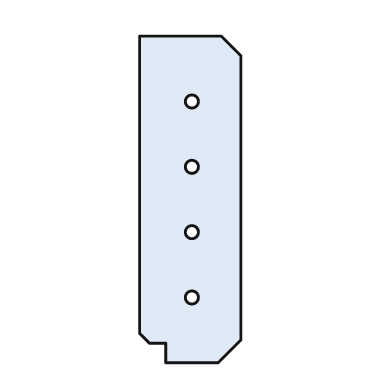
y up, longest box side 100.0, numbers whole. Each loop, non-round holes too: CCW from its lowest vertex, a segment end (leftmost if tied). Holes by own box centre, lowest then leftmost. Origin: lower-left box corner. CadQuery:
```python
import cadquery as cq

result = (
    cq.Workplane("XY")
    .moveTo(8.0, 0.0)
    .lineTo(24.0, 0.0)
    .lineTo(31.0, 7.0)
    .lineTo(31.0, 94.0)
    .lineTo(25.0, 100.0)
    .lineTo(0.0, 100.0)
    .lineTo(0.0, 9.0)
    .lineTo(3.0, 6.0)
    .lineTo(8.0, 6.0)
    .close()
    .moveTo(16.0, 20.0)
    .circle(2.0)
    .moveTo(16.0, 40.0)
    .circle(2.0)
    .moveTo(16.0, 60.0)
    .circle(2.0)
    .moveTo(16.0, 80.0)
    .circle(2.0)
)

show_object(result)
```